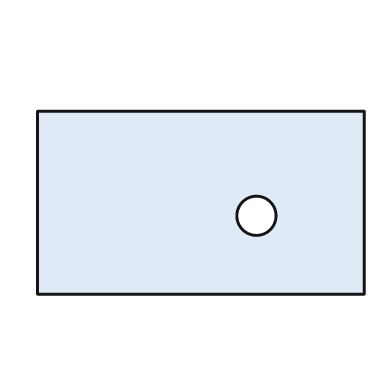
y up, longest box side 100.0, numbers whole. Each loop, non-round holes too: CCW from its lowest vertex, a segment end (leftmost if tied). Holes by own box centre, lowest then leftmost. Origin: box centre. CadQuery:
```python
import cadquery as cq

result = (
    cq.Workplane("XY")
    .moveTo(-50.0, -28.0)
    .lineTo(50.0, -28.0)
    .lineTo(50.0, 28.0)
    .lineTo(-50.0, 28.0)
    .close()
    .moveTo(17.0, -4.0)
    .circle(6.0)
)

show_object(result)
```